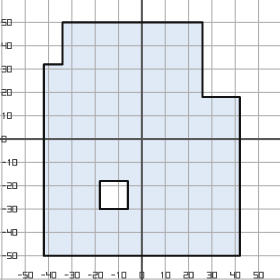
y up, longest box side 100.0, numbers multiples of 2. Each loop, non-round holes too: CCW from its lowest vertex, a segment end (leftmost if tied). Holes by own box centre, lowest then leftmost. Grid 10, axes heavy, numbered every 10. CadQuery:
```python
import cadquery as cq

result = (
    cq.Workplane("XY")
    .moveTo(-42.0, -50.0)
    .lineTo(42.0, -50.0)
    .lineTo(42.0, 18.0)
    .lineTo(26.0, 18.0)
    .lineTo(26.0, 50.0)
    .lineTo(-34.0, 50.0)
    .lineTo(-34.0, 32.0)
    .lineTo(-42.0, 32.0)
    .close()
    .moveTo(-18.0, -30.0)
    .lineTo(-6.0, -30.0)
    .lineTo(-6.0, -18.0)
    .lineTo(-18.0, -18.0)
    .close()
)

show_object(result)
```